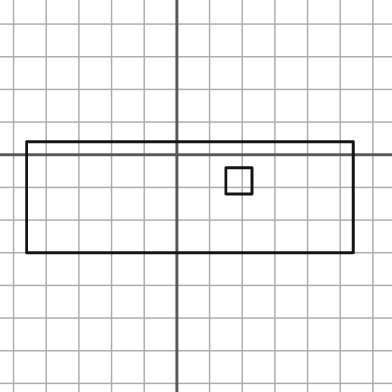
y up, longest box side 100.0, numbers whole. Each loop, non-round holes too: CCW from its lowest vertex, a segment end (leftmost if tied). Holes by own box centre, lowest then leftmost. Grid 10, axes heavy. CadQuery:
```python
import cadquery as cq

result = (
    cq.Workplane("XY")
    .moveTo(-46.0, -30.0)
    .lineTo(54.0, -30.0)
    .lineTo(54.0, 4.0)
    .lineTo(-46.0, 4.0)
    .close()
    .moveTo(15.0, -12.0)
    .lineTo(23.0, -12.0)
    .lineTo(23.0, -4.0)
    .lineTo(15.0, -4.0)
    .close()
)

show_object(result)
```